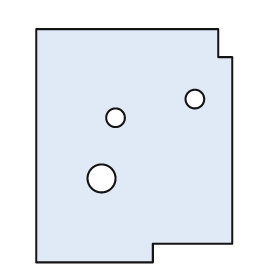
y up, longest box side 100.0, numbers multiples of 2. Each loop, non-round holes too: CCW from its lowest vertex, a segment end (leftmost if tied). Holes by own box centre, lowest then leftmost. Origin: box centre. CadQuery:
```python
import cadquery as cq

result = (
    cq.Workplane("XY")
    .moveTo(-42.0, -50.0)
    .lineTo(8.0, -50.0)
    .lineTo(8.0, -42.0)
    .lineTo(42.0, -42.0)
    .lineTo(42.0, 38.0)
    .lineTo(36.0, 38.0)
    .lineTo(36.0, 50.0)
    .lineTo(-42.0, 50.0)
    .close()
    .moveTo(-14.0, -14.0)
    .circle(6.0)
    .moveTo(-8.0, 12.0)
    .circle(4.0)
    .moveTo(26.0, 20.0)
    .circle(4.0)
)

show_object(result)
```